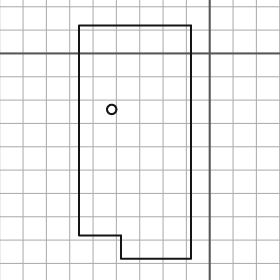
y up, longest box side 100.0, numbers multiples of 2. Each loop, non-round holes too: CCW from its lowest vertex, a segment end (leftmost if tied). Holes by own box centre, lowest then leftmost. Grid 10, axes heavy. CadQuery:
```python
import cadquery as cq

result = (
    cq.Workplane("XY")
    .moveTo(-38.0, -88.0)
    .lineTo(-8.0, -88.0)
    .lineTo(-8.0, 12.0)
    .lineTo(-56.0, 12.0)
    .lineTo(-56.0, -78.0)
    .lineTo(-38.0, -78.0)
    .close()
    .moveTo(-42.0, -24.0)
    .circle(2.0)
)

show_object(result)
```